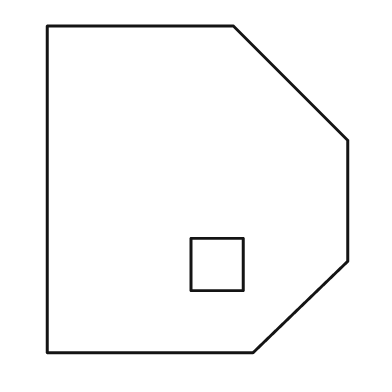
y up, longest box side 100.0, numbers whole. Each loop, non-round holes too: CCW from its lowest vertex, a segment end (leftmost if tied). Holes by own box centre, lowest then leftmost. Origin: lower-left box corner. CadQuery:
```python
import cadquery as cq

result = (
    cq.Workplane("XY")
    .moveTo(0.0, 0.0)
    .lineTo(63.0, 0.0)
    .lineTo(92.0, 28.0)
    .lineTo(92.0, 65.0)
    .lineTo(57.0, 100.0)
    .lineTo(0.0, 100.0)
    .close()
    .moveTo(44.0, 19.0)
    .lineTo(60.0, 19.0)
    .lineTo(60.0, 35.0)
    .lineTo(44.0, 35.0)
    .close()
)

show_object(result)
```